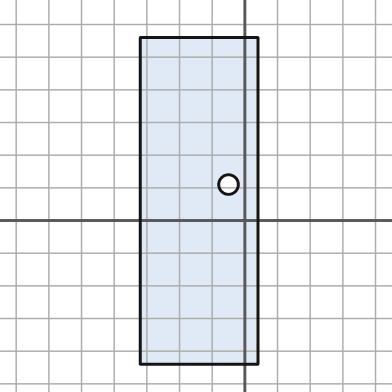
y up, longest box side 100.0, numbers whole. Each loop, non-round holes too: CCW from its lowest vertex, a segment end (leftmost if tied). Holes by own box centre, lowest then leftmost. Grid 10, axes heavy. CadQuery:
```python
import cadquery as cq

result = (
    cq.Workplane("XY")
    .moveTo(-32.0, -44.0)
    .lineTo(4.0, -44.0)
    .lineTo(4.0, 56.0)
    .lineTo(-32.0, 56.0)
    .close()
    .moveTo(-5.0, 11.0)
    .circle(3.0)
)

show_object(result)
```